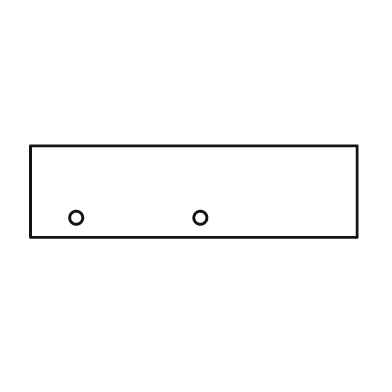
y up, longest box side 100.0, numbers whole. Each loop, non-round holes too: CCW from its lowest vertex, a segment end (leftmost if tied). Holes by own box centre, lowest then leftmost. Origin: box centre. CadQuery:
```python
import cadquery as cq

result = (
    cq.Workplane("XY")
    .moveTo(-50.0, -14.0)
    .lineTo(50.0, -14.0)
    .lineTo(50.0, 14.0)
    .lineTo(-50.0, 14.0)
    .close()
    .moveTo(-36.0, -8.0)
    .circle(2.0)
    .moveTo(2.0, -8.0)
    .circle(2.0)
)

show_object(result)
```